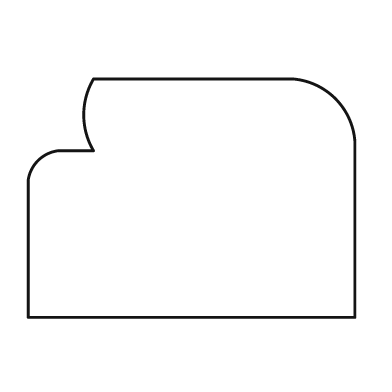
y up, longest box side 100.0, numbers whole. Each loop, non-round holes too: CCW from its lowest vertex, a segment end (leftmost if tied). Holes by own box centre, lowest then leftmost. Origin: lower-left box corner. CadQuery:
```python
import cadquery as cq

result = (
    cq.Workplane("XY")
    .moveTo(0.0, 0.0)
    .lineTo(100.0, 0.0)
    .lineTo(100.0, 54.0)
    .threePointArc((94.0, 67.0), (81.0, 73.0))
    .lineTo(20.0, 73.0)
    .threePointArc((17.0, 62.0), (20.0, 51.0))
    .lineTo(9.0, 51.0)
    .threePointArc((3.0, 48.0), (0.0, 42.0))
    .close()
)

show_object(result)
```